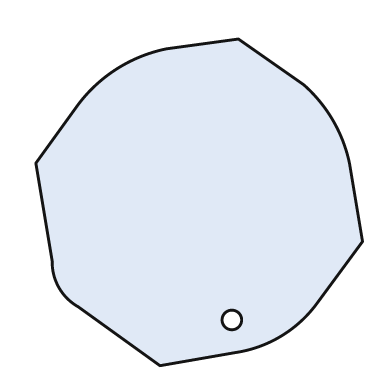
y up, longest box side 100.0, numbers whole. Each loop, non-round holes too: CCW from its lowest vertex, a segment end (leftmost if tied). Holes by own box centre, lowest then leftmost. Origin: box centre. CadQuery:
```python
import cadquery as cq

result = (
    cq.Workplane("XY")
    .moveTo(-12.0, -50.0)
    .lineTo(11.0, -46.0)
    .threePointArc((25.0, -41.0), (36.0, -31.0))
    .lineTo(50.0, -12.0)
    .lineTo(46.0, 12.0)
    .threePointArc((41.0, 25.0), (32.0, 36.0))
    .lineTo(12.0, 50.0)
    .lineTo(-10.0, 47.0)
    .threePointArc((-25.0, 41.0), (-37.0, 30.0))
    .lineTo(-50.0, 12.0)
    .lineTo(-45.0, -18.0)
    .threePointArc((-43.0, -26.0), (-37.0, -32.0))
    .close()
    .moveTo(10.0, -36.0)
    .circle(3.0)
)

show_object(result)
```